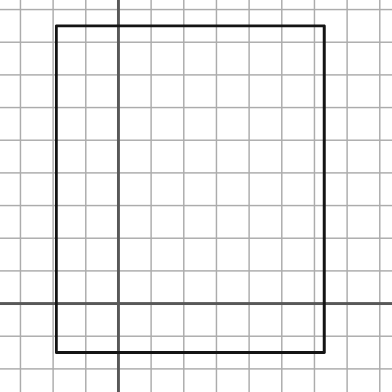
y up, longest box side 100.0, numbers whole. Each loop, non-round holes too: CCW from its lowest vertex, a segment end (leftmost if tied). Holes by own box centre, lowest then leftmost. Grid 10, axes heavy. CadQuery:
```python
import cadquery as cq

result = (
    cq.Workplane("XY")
    .moveTo(-19.0, -15.0)
    .lineTo(63.0, -15.0)
    .lineTo(63.0, 85.0)
    .lineTo(-19.0, 85.0)
    .close()
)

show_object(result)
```